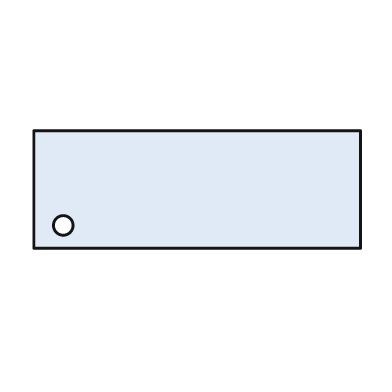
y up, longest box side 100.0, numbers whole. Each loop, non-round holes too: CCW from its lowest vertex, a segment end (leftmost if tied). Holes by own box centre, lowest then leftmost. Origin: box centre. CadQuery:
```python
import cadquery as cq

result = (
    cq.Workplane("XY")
    .moveTo(-50.0, -18.0)
    .lineTo(50.0, -18.0)
    .lineTo(50.0, 18.0)
    .lineTo(-50.0, 18.0)
    .close()
    .moveTo(-41.0, -11.0)
    .circle(3.0)
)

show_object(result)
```